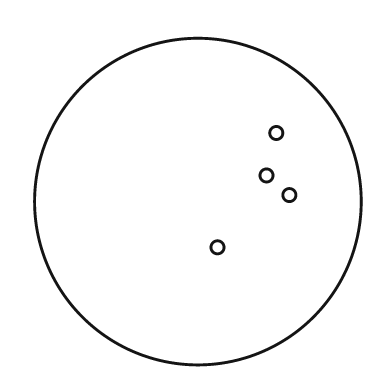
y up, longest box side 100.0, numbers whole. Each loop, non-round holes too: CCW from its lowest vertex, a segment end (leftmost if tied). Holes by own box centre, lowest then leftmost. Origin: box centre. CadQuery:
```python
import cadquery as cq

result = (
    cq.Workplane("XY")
    .moveTo(0.0, 0.0)
    .circle(50.0)
    .moveTo(6.0, -14.0)
    .circle(2.0)
    .moveTo(28.0, 2.0)
    .circle(2.0)
    .moveTo(21.0, 8.0)
    .circle(2.0)
    .moveTo(24.0, 21.0)
    .circle(2.0)
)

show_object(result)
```